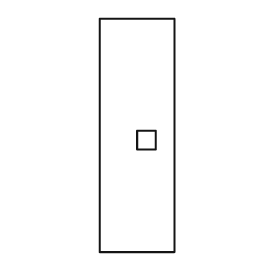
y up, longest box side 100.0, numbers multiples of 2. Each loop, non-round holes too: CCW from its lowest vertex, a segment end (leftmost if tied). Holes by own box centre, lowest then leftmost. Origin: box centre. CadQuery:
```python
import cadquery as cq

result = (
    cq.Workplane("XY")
    .moveTo(-16.0, -50.0)
    .lineTo(16.0, -50.0)
    .lineTo(16.0, 50.0)
    .lineTo(-16.0, 50.0)
    .close()
    .moveTo(0.0, -6.0)
    .lineTo(8.0, -6.0)
    .lineTo(8.0, 2.0)
    .lineTo(0.0, 2.0)
    .close()
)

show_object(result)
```